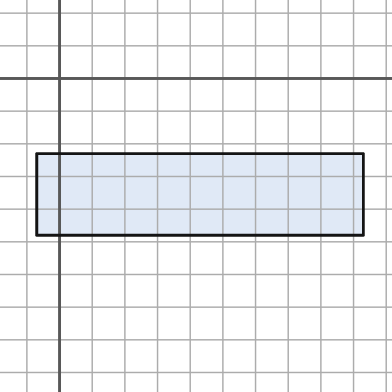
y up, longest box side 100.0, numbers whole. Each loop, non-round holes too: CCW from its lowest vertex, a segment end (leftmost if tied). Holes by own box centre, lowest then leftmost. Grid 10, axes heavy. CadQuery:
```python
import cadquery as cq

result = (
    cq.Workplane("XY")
    .moveTo(-7.0, -48.0)
    .lineTo(93.0, -48.0)
    .lineTo(93.0, -23.0)
    .lineTo(-7.0, -23.0)
    .close()
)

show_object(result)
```